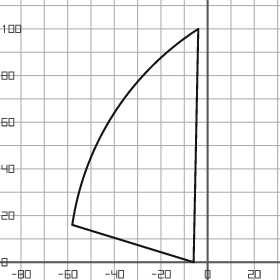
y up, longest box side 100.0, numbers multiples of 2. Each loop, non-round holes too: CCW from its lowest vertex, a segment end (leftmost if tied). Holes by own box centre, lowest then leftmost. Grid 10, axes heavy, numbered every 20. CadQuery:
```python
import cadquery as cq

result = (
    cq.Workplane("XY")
    .moveTo(-6.0, 0.0)
    .lineTo(-4.0, 100.0)
    .threePointArc((-40.0, 64.0), (-58.0, 16.0))
    .close()
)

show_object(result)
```